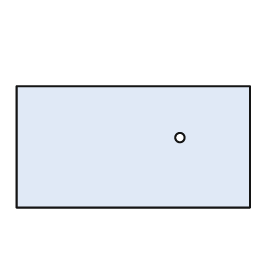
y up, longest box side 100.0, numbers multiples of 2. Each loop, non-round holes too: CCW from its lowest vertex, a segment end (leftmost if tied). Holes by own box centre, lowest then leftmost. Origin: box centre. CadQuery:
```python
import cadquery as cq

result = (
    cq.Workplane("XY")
    .moveTo(-50.0, -26.0)
    .lineTo(50.0, -26.0)
    .lineTo(50.0, 26.0)
    .lineTo(-50.0, 26.0)
    .close()
    .moveTo(20.0, 4.0)
    .circle(2.0)
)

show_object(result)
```